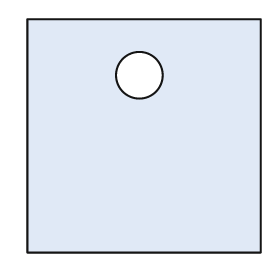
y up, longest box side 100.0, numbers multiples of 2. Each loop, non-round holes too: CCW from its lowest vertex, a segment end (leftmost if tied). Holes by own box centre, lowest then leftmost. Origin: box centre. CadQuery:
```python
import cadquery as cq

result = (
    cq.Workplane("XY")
    .moveTo(-50.0, -50.0)
    .lineTo(50.0, -50.0)
    .lineTo(50.0, 50.0)
    .lineTo(-50.0, 50.0)
    .close()
    .moveTo(-2.0, 26.0)
    .circle(10.0)
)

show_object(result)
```